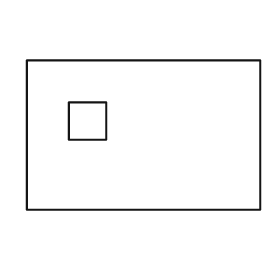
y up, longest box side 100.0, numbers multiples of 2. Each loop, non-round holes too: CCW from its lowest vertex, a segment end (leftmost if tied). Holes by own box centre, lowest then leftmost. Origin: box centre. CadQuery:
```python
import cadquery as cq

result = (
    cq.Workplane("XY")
    .moveTo(-50.0, -32.0)
    .lineTo(50.0, -32.0)
    .lineTo(50.0, 32.0)
    .lineTo(-50.0, 32.0)
    .close()
    .moveTo(-32.0, -2.0)
    .lineTo(-16.0, -2.0)
    .lineTo(-16.0, 14.0)
    .lineTo(-32.0, 14.0)
    .close()
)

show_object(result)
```